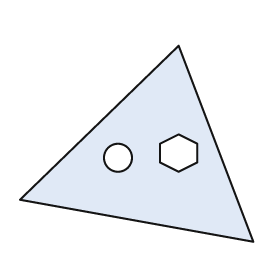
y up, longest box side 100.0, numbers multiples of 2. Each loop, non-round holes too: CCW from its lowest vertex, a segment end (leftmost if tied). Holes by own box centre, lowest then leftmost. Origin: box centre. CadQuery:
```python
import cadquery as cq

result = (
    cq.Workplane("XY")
    .moveTo(50.0, -42.0)
    .lineTo(18.0, 42.0)
    .lineTo(-50.0, -24.0)
    .close()
    .moveTo(-8.0, -6.0)
    .circle(6.0)
    .moveTo(18.0, -12.0)
    .lineTo(26.0, -8.0)
    .lineTo(26.0, 0.0)
    .lineTo(18.0, 4.0)
    .lineTo(10.0, 0.0)
    .lineTo(10.0, -8.0)
    .close()
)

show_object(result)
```